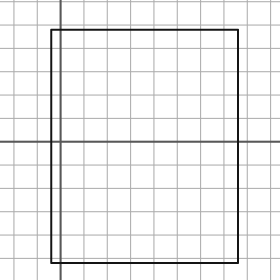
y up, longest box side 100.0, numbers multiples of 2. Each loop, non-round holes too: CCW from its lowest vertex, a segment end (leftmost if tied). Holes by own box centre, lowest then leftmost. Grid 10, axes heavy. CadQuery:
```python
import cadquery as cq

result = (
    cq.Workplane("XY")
    .moveTo(-4.0, -52.0)
    .lineTo(76.0, -52.0)
    .lineTo(76.0, 48.0)
    .lineTo(-4.0, 48.0)
    .close()
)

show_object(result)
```